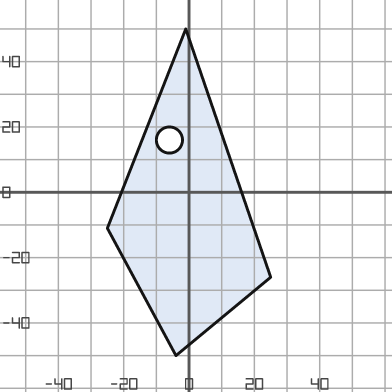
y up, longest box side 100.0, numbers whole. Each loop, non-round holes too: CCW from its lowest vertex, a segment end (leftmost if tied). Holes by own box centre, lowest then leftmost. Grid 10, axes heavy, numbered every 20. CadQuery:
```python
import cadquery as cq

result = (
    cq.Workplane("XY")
    .moveTo(-4.0, -50.0)
    .lineTo(25.0, -26.0)
    .lineTo(-1.0, 50.0)
    .lineTo(-25.0, -11.0)
    .close()
    .moveTo(-6.0, 16.0)
    .circle(4.0)
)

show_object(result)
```